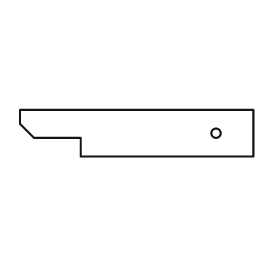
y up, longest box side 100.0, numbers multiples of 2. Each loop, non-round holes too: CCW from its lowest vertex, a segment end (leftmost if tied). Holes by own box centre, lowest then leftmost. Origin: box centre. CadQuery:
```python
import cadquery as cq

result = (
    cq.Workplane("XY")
    .moveTo(-24.0, -10.0)
    .lineTo(50.0, -10.0)
    .lineTo(50.0, 10.0)
    .lineTo(-50.0, 10.0)
    .lineTo(-50.0, 4.0)
    .lineTo(-44.0, -2.0)
    .lineTo(-24.0, -2.0)
    .close()
    .moveTo(34.0, 0.0)
    .circle(2.0)
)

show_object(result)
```